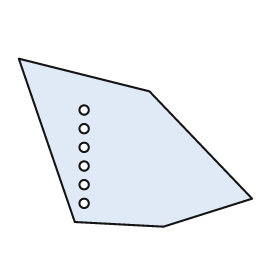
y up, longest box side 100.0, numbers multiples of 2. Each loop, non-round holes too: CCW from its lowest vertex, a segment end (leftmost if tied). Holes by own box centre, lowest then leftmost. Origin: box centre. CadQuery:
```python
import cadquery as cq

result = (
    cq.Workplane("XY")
    .moveTo(12.0, -36.0)
    .lineTo(50.0, -24.0)
    .lineTo(6.0, 22.0)
    .lineTo(-50.0, 36.0)
    .lineTo(-26.0, -34.0)
    .close()
    .moveTo(-22.0, -26.0)
    .circle(2.0)
    .moveTo(-22.0, -18.0)
    .circle(2.0)
    .moveTo(-22.0, -10.0)
    .circle(2.0)
    .moveTo(-22.0, -2.0)
    .circle(2.0)
    .moveTo(-22.0, 6.0)
    .circle(2.0)
    .moveTo(-22.0, 14.0)
    .circle(2.0)
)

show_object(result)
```